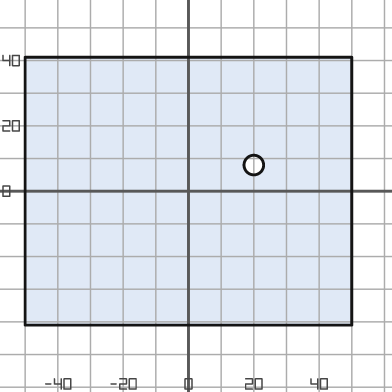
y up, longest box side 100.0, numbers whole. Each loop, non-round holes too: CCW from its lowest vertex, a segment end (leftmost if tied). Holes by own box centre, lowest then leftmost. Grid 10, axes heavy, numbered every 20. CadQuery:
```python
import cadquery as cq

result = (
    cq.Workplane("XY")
    .moveTo(-50.0, -41.0)
    .lineTo(50.0, -41.0)
    .lineTo(50.0, 41.0)
    .lineTo(-50.0, 41.0)
    .close()
    .moveTo(20.0, 8.0)
    .circle(3.0)
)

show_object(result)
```